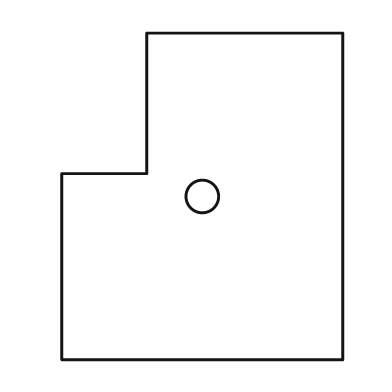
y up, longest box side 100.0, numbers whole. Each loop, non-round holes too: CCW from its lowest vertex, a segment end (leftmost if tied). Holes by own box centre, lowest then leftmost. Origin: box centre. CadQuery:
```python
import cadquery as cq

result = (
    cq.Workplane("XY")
    .moveTo(-43.0, -50.0)
    .lineTo(43.0, -50.0)
    .lineTo(43.0, 50.0)
    .lineTo(-17.0, 50.0)
    .lineTo(-17.0, 7.0)
    .lineTo(-43.0, 7.0)
    .close()
    .moveTo(0.0, 0.0)
    .circle(5.0)
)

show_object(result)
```